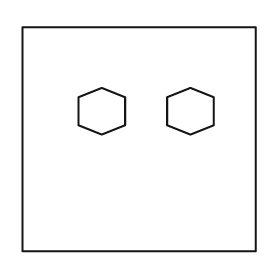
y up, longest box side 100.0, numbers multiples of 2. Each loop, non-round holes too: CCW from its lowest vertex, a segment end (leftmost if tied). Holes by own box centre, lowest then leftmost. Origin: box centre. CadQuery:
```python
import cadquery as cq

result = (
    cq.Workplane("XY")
    .moveTo(-50.0, -48.0)
    .lineTo(50.0, -48.0)
    .lineTo(50.0, 48.0)
    .lineTo(-50.0, 48.0)
    .close()
    .moveTo(-16.0, 2.0)
    .lineTo(-6.0, 6.0)
    .lineTo(-6.0, 18.0)
    .lineTo(-16.0, 22.0)
    .lineTo(-26.0, 18.0)
    .lineTo(-26.0, 6.0)
    .close()
    .moveTo(22.0, 2.0)
    .lineTo(32.0, 6.0)
    .lineTo(32.0, 18.0)
    .lineTo(22.0, 22.0)
    .lineTo(12.0, 18.0)
    .lineTo(12.0, 6.0)
    .close()
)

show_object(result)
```